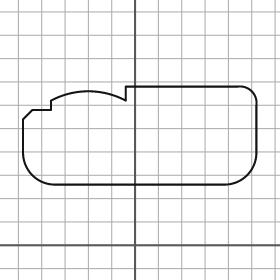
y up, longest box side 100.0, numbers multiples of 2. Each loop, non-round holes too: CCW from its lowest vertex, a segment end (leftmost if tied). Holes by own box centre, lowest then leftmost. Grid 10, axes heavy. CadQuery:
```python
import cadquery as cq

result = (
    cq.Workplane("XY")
    .moveTo(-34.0, 26.0)
    .lineTo(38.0, 26.0)
    .threePointArc((48.0, 30.0), (52.0, 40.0))
    .lineTo(52.0, 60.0)
    .threePointArc((50.0, 66.0), (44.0, 68.0))
    .lineTo(-4.0, 68.0)
    .lineTo(-4.0, 62.0)
    .threePointArc((-20.0, 66.0), (-36.0, 62.0))
    .lineTo(-36.0, 58.0)
    .lineTo(-44.0, 58.0)
    .lineTo(-48.0, 54.0)
    .lineTo(-48.0, 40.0)
    .threePointArc((-44.0, 30.0), (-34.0, 26.0))
    .close()
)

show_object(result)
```